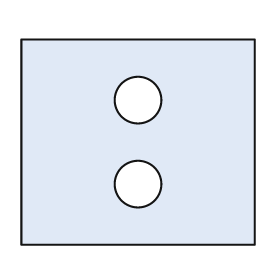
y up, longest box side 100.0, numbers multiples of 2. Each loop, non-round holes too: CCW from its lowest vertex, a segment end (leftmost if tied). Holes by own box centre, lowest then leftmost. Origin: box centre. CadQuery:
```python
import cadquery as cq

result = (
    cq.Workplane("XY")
    .moveTo(-50.0, -44.0)
    .lineTo(50.0, -44.0)
    .lineTo(50.0, 44.0)
    .lineTo(-50.0, 44.0)
    .close()
    .moveTo(0.0, -18.0)
    .circle(10.0)
    .moveTo(0.0, 18.0)
    .circle(10.0)
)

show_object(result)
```